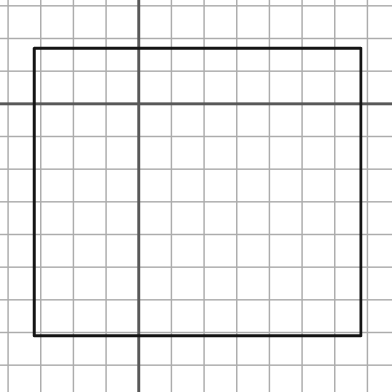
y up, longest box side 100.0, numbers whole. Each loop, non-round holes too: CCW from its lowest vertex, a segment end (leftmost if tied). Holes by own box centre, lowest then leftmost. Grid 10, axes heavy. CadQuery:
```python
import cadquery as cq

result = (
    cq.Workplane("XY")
    .moveTo(-32.0, -71.0)
    .lineTo(68.0, -71.0)
    .lineTo(68.0, 17.0)
    .lineTo(-32.0, 17.0)
    .close()
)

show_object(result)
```